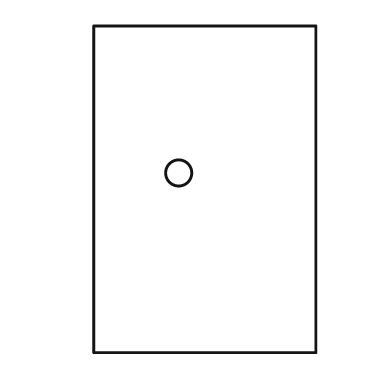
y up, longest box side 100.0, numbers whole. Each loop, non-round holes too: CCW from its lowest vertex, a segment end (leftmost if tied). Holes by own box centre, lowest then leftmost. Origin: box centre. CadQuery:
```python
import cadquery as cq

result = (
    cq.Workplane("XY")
    .moveTo(-34.0, -50.0)
    .lineTo(34.0, -50.0)
    .lineTo(34.0, 50.0)
    .lineTo(-34.0, 50.0)
    .close()
    .moveTo(-8.0, 5.0)
    .circle(4.0)
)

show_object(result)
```